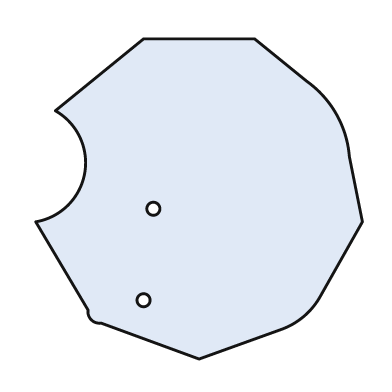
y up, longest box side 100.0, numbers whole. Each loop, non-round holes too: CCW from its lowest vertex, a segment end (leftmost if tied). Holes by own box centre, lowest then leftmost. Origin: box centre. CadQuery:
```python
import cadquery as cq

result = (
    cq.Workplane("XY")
    .moveTo(0.0, -49.0)
    .lineTo(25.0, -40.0)
    .threePointArc((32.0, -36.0), (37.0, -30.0))
    .lineTo(50.0, -7.0)
    .lineTo(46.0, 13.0)
    .threePointArc((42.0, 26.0), (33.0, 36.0))
    .lineTo(17.0, 49.0)
    .lineTo(-17.0, 49.0)
    .lineTo(-44.0, 27.0)
    .threePointArc((-35.0, 8.0), (-50.0, -7.0))
    .lineTo(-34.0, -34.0)
    .threePointArc((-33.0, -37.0), (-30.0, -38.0))
    .close()
    .moveTo(-17.0, -31.0)
    .circle(2.0)
    .moveTo(-14.0, -3.0)
    .circle(2.0)
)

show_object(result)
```